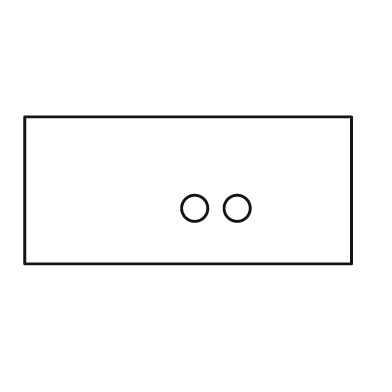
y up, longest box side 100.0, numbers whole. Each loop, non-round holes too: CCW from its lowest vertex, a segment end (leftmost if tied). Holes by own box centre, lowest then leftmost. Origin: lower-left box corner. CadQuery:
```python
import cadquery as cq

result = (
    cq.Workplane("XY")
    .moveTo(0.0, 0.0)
    .lineTo(100.0, 0.0)
    .lineTo(100.0, 45.0)
    .lineTo(0.0, 45.0)
    .close()
    .moveTo(52.0, 17.0)
    .circle(4.0)
    .moveTo(65.0, 17.0)
    .circle(4.0)
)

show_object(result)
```